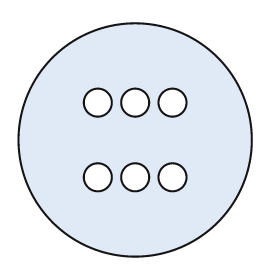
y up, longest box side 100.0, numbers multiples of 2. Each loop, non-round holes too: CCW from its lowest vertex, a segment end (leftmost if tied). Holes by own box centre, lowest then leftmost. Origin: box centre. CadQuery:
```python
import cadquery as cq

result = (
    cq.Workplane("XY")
    .moveTo(0.0, 0.0)
    .circle(50.0)
    .moveTo(-16.0, -16.0)
    .circle(6.0)
    .moveTo(0.0, -16.0)
    .circle(6.0)
    .moveTo(16.0, -16.0)
    .circle(6.0)
    .moveTo(-16.0, 16.0)
    .circle(6.0)
    .moveTo(0.0, 16.0)
    .circle(6.0)
    .moveTo(16.0, 16.0)
    .circle(6.0)
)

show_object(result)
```